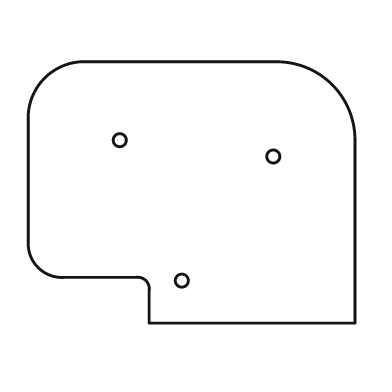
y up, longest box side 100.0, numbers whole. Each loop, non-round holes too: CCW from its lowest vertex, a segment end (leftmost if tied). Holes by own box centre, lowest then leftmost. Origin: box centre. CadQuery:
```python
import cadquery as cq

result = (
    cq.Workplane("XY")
    .moveTo(-13.0, -40.0)
    .lineTo(50.0, -40.0)
    .lineTo(50.0, 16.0)
    .threePointArc((43.0, 33.0), (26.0, 40.0))
    .lineTo(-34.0, 40.0)
    .threePointArc((-45.0, 35.0), (-50.0, 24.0))
    .lineTo(-50.0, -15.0)
    .threePointArc((-47.0, -23.0), (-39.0, -26.0))
    .lineTo(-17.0, -26.0)
    .threePointArc((-14.0, -27.0), (-13.0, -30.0))
    .close()
    .moveTo(-3.0, -27.0)
    .circle(2.0)
    .moveTo(25.0, 11.0)
    .circle(2.0)
    .moveTo(-22.0, 16.0)
    .circle(2.0)
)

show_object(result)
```